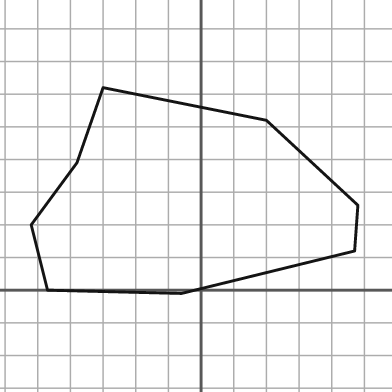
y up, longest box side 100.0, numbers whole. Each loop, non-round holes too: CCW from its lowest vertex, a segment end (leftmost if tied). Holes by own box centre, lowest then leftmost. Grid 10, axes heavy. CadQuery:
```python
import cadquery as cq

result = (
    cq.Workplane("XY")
    .moveTo(-6.0, -1.0)
    .lineTo(47.0, 12.0)
    .lineTo(48.0, 26.0)
    .lineTo(20.0, 52.0)
    .lineTo(-30.0, 62.0)
    .lineTo(-38.0, 39.0)
    .lineTo(-52.0, 20.0)
    .lineTo(-47.0, 0.0)
    .close()
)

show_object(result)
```